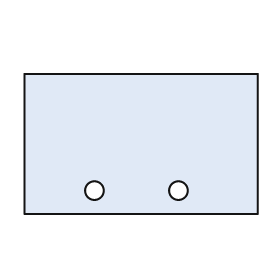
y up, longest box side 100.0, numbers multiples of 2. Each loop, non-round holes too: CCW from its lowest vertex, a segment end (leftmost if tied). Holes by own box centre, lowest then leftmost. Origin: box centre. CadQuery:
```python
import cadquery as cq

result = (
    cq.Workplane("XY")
    .moveTo(-50.0, -30.0)
    .lineTo(50.0, -30.0)
    .lineTo(50.0, 30.0)
    .lineTo(-50.0, 30.0)
    .close()
    .moveTo(-20.0, -20.0)
    .circle(4.0)
    .moveTo(16.0, -20.0)
    .circle(4.0)
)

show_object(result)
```